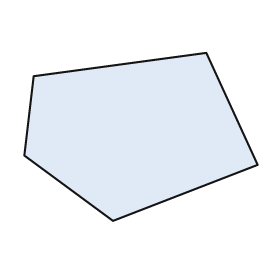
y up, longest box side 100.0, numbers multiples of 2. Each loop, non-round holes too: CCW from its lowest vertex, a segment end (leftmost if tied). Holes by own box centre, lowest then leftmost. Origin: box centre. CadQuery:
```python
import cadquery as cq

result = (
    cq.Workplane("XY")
    .moveTo(-12.0, -36.0)
    .lineTo(50.0, -12.0)
    .lineTo(28.0, 36.0)
    .lineTo(-46.0, 26.0)
    .lineTo(-50.0, -8.0)
    .close()
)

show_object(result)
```